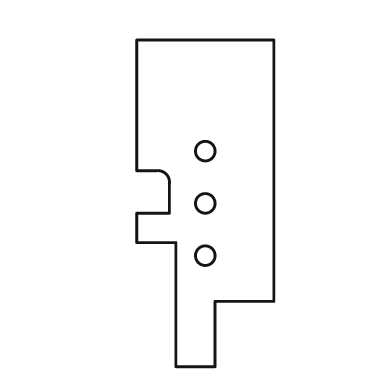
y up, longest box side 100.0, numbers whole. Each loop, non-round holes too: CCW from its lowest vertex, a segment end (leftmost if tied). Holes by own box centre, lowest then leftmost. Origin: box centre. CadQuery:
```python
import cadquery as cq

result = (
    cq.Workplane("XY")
    .moveTo(-9.0, -50.0)
    .lineTo(3.0, -50.0)
    .lineTo(3.0, -30.0)
    .lineTo(21.0, -30.0)
    .lineTo(21.0, 50.0)
    .lineTo(-21.0, 50.0)
    .lineTo(-21.0, 10.0)
    .lineTo(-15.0, 10.0)
    .threePointArc((-12.0, 9.0), (-11.0, 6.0))
    .lineTo(-11.0, -3.0)
    .lineTo(-21.0, -3.0)
    .lineTo(-21.0, -12.0)
    .lineTo(-9.0, -12.0)
    .close()
    .moveTo(0.0, -16.0)
    .circle(3.0)
    .moveTo(0.0, 0.0)
    .circle(3.0)
    .moveTo(0.0, 16.0)
    .circle(3.0)
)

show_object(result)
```